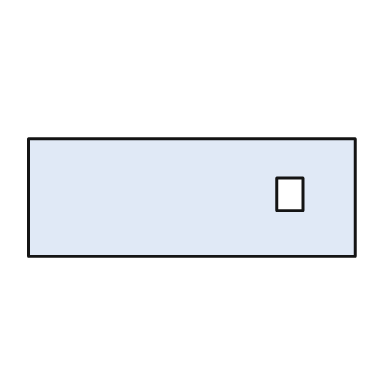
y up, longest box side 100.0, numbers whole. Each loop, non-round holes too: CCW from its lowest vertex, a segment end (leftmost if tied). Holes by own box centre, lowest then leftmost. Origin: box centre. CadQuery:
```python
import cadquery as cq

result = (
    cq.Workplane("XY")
    .moveTo(-50.0, -18.0)
    .lineTo(50.0, -18.0)
    .lineTo(50.0, 18.0)
    .lineTo(-50.0, 18.0)
    .close()
    .moveTo(26.0, -4.0)
    .lineTo(34.0, -4.0)
    .lineTo(34.0, 6.0)
    .lineTo(26.0, 6.0)
    .close()
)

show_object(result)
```